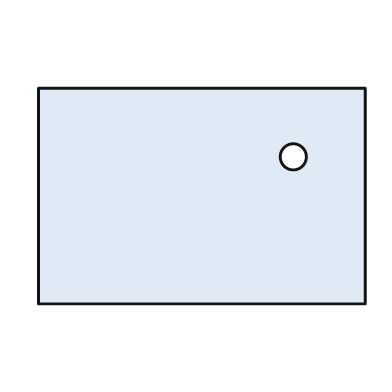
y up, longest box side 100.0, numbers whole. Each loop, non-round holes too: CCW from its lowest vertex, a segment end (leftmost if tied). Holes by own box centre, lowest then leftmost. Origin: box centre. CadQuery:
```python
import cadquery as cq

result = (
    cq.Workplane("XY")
    .moveTo(-50.0, -33.0)
    .lineTo(50.0, -33.0)
    .lineTo(50.0, 33.0)
    .lineTo(-50.0, 33.0)
    .close()
    .moveTo(28.0, 12.0)
    .circle(4.0)
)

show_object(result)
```